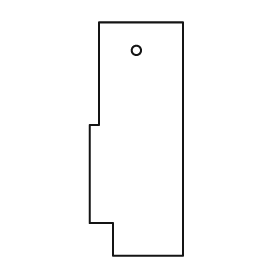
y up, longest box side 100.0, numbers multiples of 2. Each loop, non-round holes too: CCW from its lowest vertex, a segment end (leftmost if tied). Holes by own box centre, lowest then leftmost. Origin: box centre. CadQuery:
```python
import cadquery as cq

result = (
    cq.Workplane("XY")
    .moveTo(-10.0, -50.0)
    .lineTo(20.0, -50.0)
    .lineTo(20.0, 50.0)
    .lineTo(-16.0, 50.0)
    .lineTo(-16.0, 6.0)
    .lineTo(-20.0, 6.0)
    .lineTo(-20.0, -36.0)
    .lineTo(-10.0, -36.0)
    .close()
    .moveTo(0.0, 38.0)
    .circle(2.0)
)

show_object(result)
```